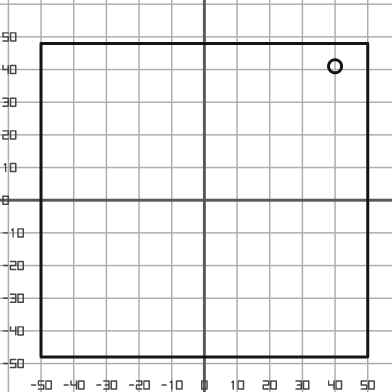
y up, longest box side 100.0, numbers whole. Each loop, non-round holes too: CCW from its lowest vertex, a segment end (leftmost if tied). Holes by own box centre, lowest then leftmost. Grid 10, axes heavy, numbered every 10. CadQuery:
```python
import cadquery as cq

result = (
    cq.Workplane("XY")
    .moveTo(-50.0, -48.0)
    .lineTo(50.0, -48.0)
    .lineTo(50.0, 48.0)
    .lineTo(-50.0, 48.0)
    .close()
    .moveTo(40.0, 41.0)
    .circle(2.0)
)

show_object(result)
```